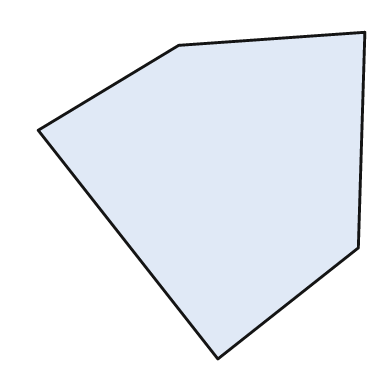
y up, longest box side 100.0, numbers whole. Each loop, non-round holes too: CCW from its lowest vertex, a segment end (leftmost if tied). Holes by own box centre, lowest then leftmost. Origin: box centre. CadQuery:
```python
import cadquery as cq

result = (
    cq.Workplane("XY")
    .moveTo(5.0, -50.0)
    .lineTo(48.0, -16.0)
    .lineTo(50.0, 50.0)
    .lineTo(-7.0, 46.0)
    .lineTo(-50.0, 20.0)
    .close()
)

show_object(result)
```